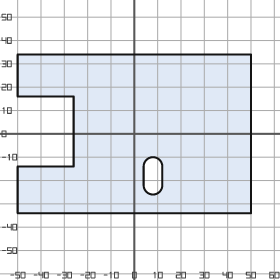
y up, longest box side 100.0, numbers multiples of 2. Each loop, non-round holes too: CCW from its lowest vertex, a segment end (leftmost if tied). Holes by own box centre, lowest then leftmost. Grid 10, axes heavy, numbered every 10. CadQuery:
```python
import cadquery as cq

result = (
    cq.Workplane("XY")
    .moveTo(-50.0, -34.0)
    .lineTo(50.0, -34.0)
    .lineTo(50.0, 34.0)
    .lineTo(-50.0, 34.0)
    .lineTo(-50.0, 16.0)
    .lineTo(-26.0, 16.0)
    .lineTo(-26.0, -14.0)
    .lineTo(-50.0, -14.0)
    .close()
    .moveTo(4.0, -22.0)
    .threePointArc((8.0, -26.0), (12.0, -22.0))
    .lineTo(12.0, -14.0)
    .threePointArc((8.0, -10.0), (4.0, -14.0))
    .close()
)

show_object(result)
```